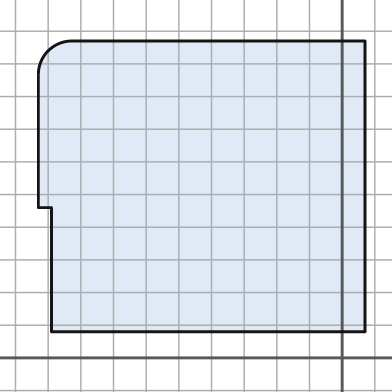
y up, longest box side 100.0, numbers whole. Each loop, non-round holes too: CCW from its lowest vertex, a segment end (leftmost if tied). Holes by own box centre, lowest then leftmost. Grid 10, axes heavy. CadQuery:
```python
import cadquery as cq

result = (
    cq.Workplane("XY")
    .moveTo(-89.0, 8.0)
    .lineTo(7.0, 8.0)
    .lineTo(7.0, 97.0)
    .lineTo(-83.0, 97.0)
    .threePointArc((-90.0, 94.0), (-93.0, 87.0))
    .lineTo(-93.0, 46.0)
    .lineTo(-89.0, 46.0)
    .close()
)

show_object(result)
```